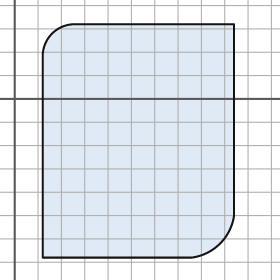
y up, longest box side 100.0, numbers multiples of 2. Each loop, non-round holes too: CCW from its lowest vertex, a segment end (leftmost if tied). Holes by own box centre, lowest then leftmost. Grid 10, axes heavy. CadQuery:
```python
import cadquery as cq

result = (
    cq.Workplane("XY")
    .moveTo(12.0, -68.0)
    .lineTo(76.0, -68.0)
    .threePointArc((88.0, -62.0), (94.0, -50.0))
    .lineTo(94.0, 32.0)
    .lineTo(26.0, 32.0)
    .threePointArc((16.0, 28.0), (12.0, 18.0))
    .close()
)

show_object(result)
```